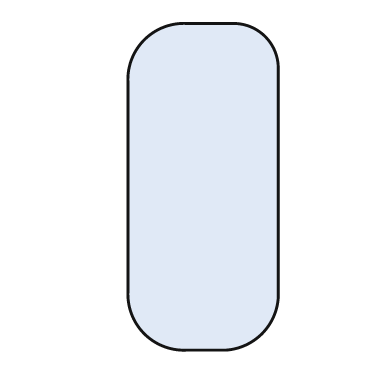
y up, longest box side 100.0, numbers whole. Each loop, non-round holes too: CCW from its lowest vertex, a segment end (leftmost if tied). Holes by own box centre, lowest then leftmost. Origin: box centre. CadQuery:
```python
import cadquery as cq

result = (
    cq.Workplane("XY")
    .moveTo(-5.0, -50.0)
    .lineTo(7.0, -50.0)
    .threePointArc((18.0, -45.0), (23.0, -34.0))
    .lineTo(23.0, 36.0)
    .threePointArc((19.0, 46.0), (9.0, 50.0))
    .lineTo(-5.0, 50.0)
    .threePointArc((-18.0, 45.0), (-23.0, 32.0))
    .lineTo(-23.0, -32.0)
    .threePointArc((-18.0, -45.0), (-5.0, -50.0))
    .close()
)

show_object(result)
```